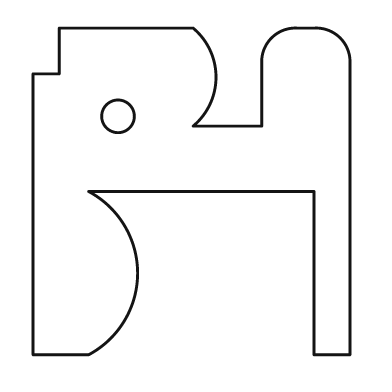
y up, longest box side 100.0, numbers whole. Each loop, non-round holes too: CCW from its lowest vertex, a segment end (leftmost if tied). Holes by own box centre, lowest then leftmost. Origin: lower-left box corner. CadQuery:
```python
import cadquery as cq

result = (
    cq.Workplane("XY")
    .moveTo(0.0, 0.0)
    .lineTo(17.0, 0.0)
    .threePointArc((32.0, 25.0), (17.0, 50.0))
    .lineTo(86.0, 50.0)
    .lineTo(86.0, 0.0)
    .lineTo(97.0, 0.0)
    .lineTo(97.0, 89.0)
    .threePointArc((94.0, 97.0), (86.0, 100.0))
    .lineTo(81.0, 100.0)
    .threePointArc((73.0, 97.0), (70.0, 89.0))
    .lineTo(70.0, 70.0)
    .lineTo(49.0, 70.0)
    .threePointArc((56.0, 85.0), (49.0, 100.0))
    .lineTo(8.0, 100.0)
    .lineTo(8.0, 86.0)
    .lineTo(0.0, 86.0)
    .close()
    .moveTo(26.0, 73.0)
    .circle(5.0)
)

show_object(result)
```